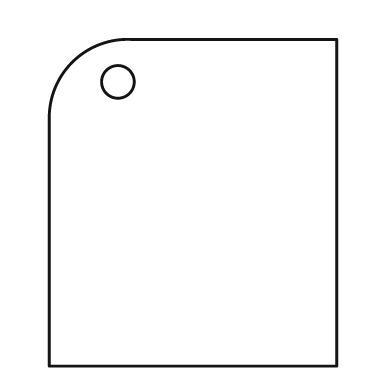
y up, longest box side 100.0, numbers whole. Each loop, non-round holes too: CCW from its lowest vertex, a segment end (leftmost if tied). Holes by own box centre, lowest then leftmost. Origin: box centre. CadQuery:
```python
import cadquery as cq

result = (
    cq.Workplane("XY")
    .moveTo(-44.0, -50.0)
    .lineTo(44.0, -50.0)
    .lineTo(44.0, 50.0)
    .lineTo(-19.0, 50.0)
    .threePointArc((-37.0, 43.0), (-44.0, 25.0))
    .close()
    .moveTo(-23.0, 37.0)
    .circle(5.0)
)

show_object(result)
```